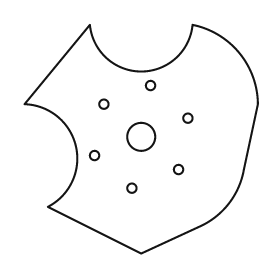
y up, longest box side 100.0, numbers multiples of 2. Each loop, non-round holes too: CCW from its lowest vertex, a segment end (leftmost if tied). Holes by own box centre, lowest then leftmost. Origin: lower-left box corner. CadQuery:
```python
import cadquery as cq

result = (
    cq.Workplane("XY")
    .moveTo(50.0, 0.0)
    .lineTo(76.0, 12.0)
    .threePointArc((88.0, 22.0), (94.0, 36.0))
    .lineTo(100.0, 64.0)
    .threePointArc((92.0, 86.0), (72.0, 98.0))
    .threePointArc((50.0, 78.0), (28.0, 98.0))
    .lineTo(0.0, 64.0)
    .threePointArc((22.0, 46.0), (10.0, 20.0))
    .close()
    .moveTo(46.0, 28.0)
    .circle(2.0)
    .moveTo(66.0, 36.0)
    .circle(2.0)
    .moveTo(30.0, 42.0)
    .circle(2.0)
    .moveTo(50.0, 50.0)
    .circle(6.0)
    .moveTo(70.0, 58.0)
    .circle(2.0)
    .moveTo(34.0, 64.0)
    .circle(2.0)
    .moveTo(54.0, 72.0)
    .circle(2.0)
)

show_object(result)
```